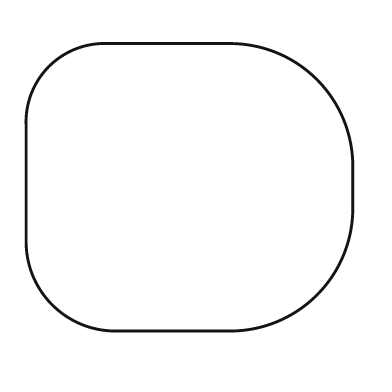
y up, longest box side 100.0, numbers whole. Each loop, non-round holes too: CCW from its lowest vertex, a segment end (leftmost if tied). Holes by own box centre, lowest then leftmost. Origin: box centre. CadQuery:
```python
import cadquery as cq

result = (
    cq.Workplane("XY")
    .moveTo(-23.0, -44.0)
    .lineTo(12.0, -44.0)
    .threePointArc((39.0, -33.0), (50.0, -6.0))
    .lineTo(50.0, 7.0)
    .threePointArc((39.0, 33.0), (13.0, 44.0))
    .lineTo(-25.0, 44.0)
    .threePointArc((-43.0, 37.0), (-50.0, 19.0))
    .lineTo(-50.0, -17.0)
    .threePointArc((-42.0, -36.0), (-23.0, -44.0))
    .close()
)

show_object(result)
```